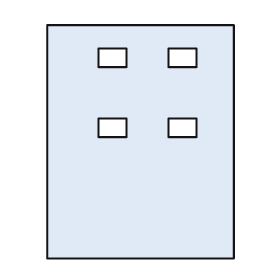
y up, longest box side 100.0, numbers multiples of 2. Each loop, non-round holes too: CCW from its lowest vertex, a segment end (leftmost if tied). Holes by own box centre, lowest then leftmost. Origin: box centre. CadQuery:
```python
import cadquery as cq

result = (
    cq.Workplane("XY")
    .moveTo(-40.0, -50.0)
    .lineTo(40.0, -50.0)
    .lineTo(40.0, 50.0)
    .lineTo(-40.0, 50.0)
    .close()
    .moveTo(-18.0, 2.0)
    .lineTo(-6.0, 2.0)
    .lineTo(-6.0, 10.0)
    .lineTo(-18.0, 10.0)
    .close()
    .moveTo(12.0, 2.0)
    .lineTo(24.0, 2.0)
    .lineTo(24.0, 10.0)
    .lineTo(12.0, 10.0)
    .close()
    .moveTo(-18.0, 32.0)
    .lineTo(-6.0, 32.0)
    .lineTo(-6.0, 40.0)
    .lineTo(-18.0, 40.0)
    .close()
    .moveTo(12.0, 32.0)
    .lineTo(24.0, 32.0)
    .lineTo(24.0, 40.0)
    .lineTo(12.0, 40.0)
    .close()
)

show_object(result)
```